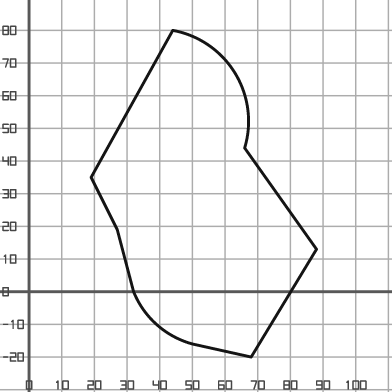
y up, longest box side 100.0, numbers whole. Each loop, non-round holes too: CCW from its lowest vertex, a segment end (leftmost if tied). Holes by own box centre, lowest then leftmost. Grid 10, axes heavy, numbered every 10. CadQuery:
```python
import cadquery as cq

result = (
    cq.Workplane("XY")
    .moveTo(68.0, -20.0)
    .lineTo(88.0, 13.0)
    .lineTo(66.0, 44.0)
    .threePointArc((63.0, 67.0), (44.0, 80.0))
    .lineTo(19.0, 35.0)
    .lineTo(27.0, 19.0)
    .lineTo(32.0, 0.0)
    .threePointArc((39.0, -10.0), (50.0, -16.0))
    .close()
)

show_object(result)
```